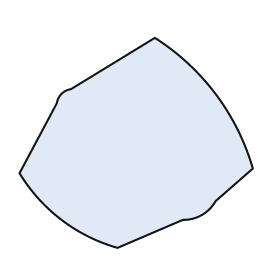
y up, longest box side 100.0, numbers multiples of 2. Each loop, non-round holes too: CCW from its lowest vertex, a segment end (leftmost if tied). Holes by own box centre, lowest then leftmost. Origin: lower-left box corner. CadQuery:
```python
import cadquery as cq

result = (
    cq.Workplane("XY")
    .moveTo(42.0, 0.0)
    .lineTo(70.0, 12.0)
    .threePointArc((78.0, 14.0), (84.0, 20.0))
    .lineTo(100.0, 34.0)
    .threePointArc((84.0, 66.0), (58.0, 90.0))
    .lineTo(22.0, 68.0)
    .threePointArc((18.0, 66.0), (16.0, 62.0))
    .lineTo(0.0, 32.0)
    .threePointArc((18.0, 12.0), (42.0, 0.0))
    .close()
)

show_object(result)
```